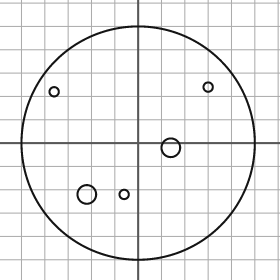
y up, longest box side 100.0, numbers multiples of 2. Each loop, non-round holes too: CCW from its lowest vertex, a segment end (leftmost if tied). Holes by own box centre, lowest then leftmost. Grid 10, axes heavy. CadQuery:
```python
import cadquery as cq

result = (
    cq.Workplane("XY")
    .moveTo(0.0, 0.0)
    .circle(50.0)
    .moveTo(-22.0, -22.0)
    .circle(4.0)
    .moveTo(-6.0, -22.0)
    .circle(2.0)
    .moveTo(14.0, -2.0)
    .circle(4.0)
    .moveTo(-36.0, 22.0)
    .circle(2.0)
    .moveTo(30.0, 24.0)
    .circle(2.0)
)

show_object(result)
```